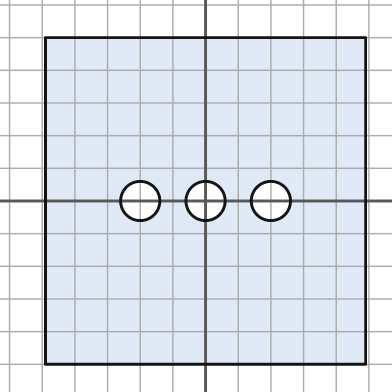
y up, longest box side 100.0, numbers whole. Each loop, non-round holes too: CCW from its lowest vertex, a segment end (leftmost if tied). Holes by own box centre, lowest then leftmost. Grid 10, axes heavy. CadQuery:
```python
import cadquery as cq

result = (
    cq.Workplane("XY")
    .moveTo(-49.0, -50.0)
    .lineTo(49.0, -50.0)
    .lineTo(49.0, 50.0)
    .lineTo(-49.0, 50.0)
    .close()
    .moveTo(-20.0, 0.0)
    .circle(6.0)
    .moveTo(0.0, 0.0)
    .circle(6.0)
    .moveTo(20.0, 0.0)
    .circle(6.0)
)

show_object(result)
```